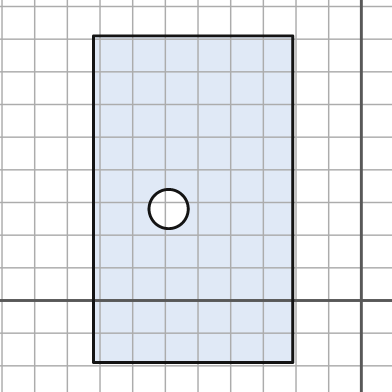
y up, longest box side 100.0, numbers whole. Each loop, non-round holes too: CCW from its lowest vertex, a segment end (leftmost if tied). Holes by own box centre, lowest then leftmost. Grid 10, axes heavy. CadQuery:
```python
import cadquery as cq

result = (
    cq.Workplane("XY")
    .moveTo(-82.0, -19.0)
    .lineTo(-21.0, -19.0)
    .lineTo(-21.0, 81.0)
    .lineTo(-82.0, 81.0)
    .close()
    .moveTo(-59.0, 28.0)
    .circle(6.0)
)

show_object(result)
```